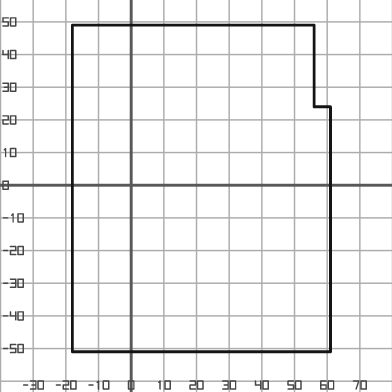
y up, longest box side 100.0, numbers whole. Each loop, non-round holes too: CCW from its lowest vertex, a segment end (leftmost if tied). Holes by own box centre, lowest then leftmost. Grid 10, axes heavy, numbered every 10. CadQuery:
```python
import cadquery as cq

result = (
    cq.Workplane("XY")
    .moveTo(-18.0, -51.0)
    .lineTo(61.0, -51.0)
    .lineTo(61.0, 24.0)
    .lineTo(56.0, 24.0)
    .lineTo(56.0, 49.0)
    .lineTo(-18.0, 49.0)
    .close()
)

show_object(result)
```